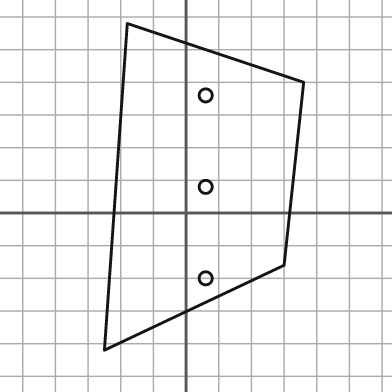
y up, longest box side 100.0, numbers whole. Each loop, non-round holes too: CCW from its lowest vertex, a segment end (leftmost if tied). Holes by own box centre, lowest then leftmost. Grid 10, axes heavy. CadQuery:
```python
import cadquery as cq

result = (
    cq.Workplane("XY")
    .moveTo(-25.0, -42.0)
    .lineTo(30.0, -16.0)
    .lineTo(36.0, 40.0)
    .lineTo(-18.0, 58.0)
    .close()
    .moveTo(6.0, -20.0)
    .circle(2.0)
    .moveTo(6.0, 8.0)
    .circle(2.0)
    .moveTo(6.0, 36.0)
    .circle(2.0)
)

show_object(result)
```